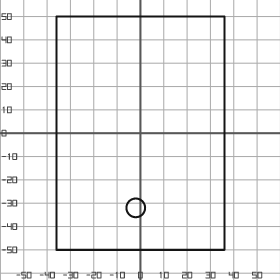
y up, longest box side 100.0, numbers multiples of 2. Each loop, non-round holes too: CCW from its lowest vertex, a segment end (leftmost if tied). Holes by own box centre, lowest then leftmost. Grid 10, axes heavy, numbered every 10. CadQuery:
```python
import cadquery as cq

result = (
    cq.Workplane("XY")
    .moveTo(-36.0, -50.0)
    .lineTo(36.0, -50.0)
    .lineTo(36.0, 50.0)
    .lineTo(-36.0, 50.0)
    .close()
    .moveTo(-2.0, -32.0)
    .circle(4.0)
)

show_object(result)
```